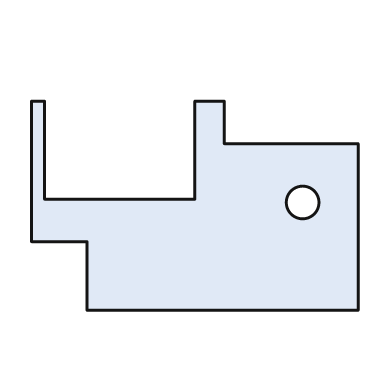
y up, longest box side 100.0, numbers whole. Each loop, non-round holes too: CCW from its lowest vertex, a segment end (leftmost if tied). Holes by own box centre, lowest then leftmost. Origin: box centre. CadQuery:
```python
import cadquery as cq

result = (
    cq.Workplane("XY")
    .moveTo(-33.0, -32.0)
    .lineTo(50.0, -32.0)
    .lineTo(50.0, 19.0)
    .lineTo(9.0, 19.0)
    .lineTo(9.0, 32.0)
    .lineTo(0.0, 32.0)
    .lineTo(0.0, 2.0)
    .lineTo(-46.0, 2.0)
    .lineTo(-46.0, 32.0)
    .lineTo(-50.0, 32.0)
    .lineTo(-50.0, -11.0)
    .lineTo(-33.0, -11.0)
    .close()
    .moveTo(33.0, 1.0)
    .circle(5.0)
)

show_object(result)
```